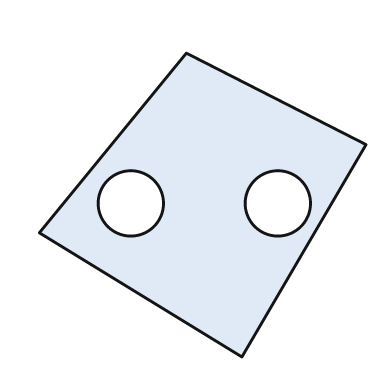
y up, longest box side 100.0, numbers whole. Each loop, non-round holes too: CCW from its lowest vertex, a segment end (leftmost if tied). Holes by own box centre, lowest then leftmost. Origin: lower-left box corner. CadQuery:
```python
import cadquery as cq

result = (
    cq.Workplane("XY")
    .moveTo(62.0, 0.0)
    .lineTo(100.0, 65.0)
    .lineTo(45.0, 93.0)
    .lineTo(0.0, 38.0)
    .close()
    .moveTo(28.0, 47.0)
    .circle(10.0)
    .moveTo(73.0, 47.0)
    .circle(10.0)
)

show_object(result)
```